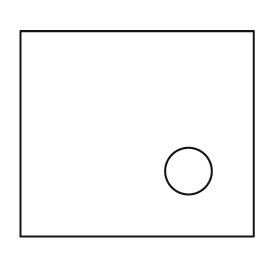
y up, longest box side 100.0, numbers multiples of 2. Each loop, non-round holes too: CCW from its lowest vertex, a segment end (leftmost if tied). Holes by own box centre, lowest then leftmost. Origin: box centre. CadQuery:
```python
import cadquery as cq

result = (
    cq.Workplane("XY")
    .moveTo(-50.0, -44.0)
    .lineTo(50.0, -44.0)
    .lineTo(50.0, 44.0)
    .lineTo(-50.0, 44.0)
    .close()
    .moveTo(22.0, -16.0)
    .circle(10.0)
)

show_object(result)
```